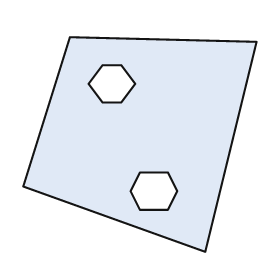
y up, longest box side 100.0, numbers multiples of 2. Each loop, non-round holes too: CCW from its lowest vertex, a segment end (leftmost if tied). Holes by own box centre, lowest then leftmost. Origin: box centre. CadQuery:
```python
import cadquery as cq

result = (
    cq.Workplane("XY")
    .moveTo(28.0, -46.0)
    .lineTo(50.0, 44.0)
    .lineTo(-30.0, 46.0)
    .lineTo(-50.0, -18.0)
    .close()
    .moveTo(0.0, -28.0)
    .lineTo(12.0, -28.0)
    .lineTo(16.0, -20.0)
    .lineTo(12.0, -12.0)
    .lineTo(0.0, -12.0)
    .lineTo(-4.0, -20.0)
    .close()
    .moveTo(-16.0, 18.0)
    .lineTo(-8.0, 18.0)
    .lineTo(-2.0, 26.0)
    .lineTo(-8.0, 34.0)
    .lineTo(-16.0, 34.0)
    .lineTo(-22.0, 26.0)
    .close()
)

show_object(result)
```